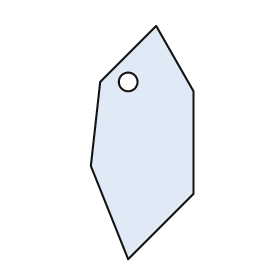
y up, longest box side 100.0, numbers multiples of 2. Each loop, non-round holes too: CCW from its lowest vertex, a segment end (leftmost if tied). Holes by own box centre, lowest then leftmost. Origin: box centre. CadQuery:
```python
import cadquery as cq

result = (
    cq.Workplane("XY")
    .moveTo(-6.0, -50.0)
    .lineTo(22.0, -22.0)
    .lineTo(22.0, 22.0)
    .lineTo(6.0, 50.0)
    .lineTo(-18.0, 26.0)
    .lineTo(-22.0, -10.0)
    .close()
    .moveTo(-6.0, 26.0)
    .circle(4.0)
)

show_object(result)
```